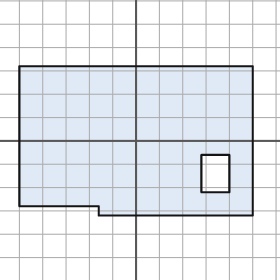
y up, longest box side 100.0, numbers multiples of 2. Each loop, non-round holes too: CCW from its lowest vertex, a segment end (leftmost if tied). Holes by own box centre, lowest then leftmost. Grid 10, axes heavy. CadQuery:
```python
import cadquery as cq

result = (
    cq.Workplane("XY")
    .moveTo(-16.0, -32.0)
    .lineTo(50.0, -32.0)
    .lineTo(50.0, 32.0)
    .lineTo(-50.0, 32.0)
    .lineTo(-50.0, -28.0)
    .lineTo(-16.0, -28.0)
    .close()
    .moveTo(28.0, -22.0)
    .lineTo(40.0, -22.0)
    .lineTo(40.0, -6.0)
    .lineTo(28.0, -6.0)
    .close()
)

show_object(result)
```